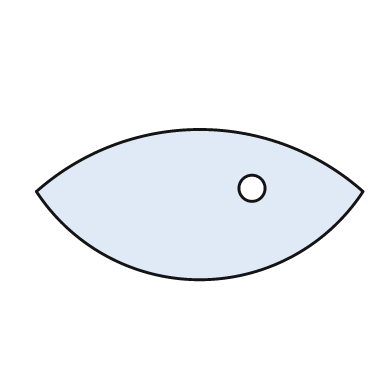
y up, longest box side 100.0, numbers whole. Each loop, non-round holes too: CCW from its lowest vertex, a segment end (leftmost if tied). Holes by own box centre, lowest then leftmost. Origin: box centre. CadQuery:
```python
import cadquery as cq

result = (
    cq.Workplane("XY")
    .moveTo(-50.0, 4.0)
    .threePointArc((0.0, -23.0), (50.0, 4.0))
    .threePointArc((0.0, 23.0), (-50.0, 4.0))
    .close()
    .moveTo(16.0, 5.0)
    .circle(4.0)
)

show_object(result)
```